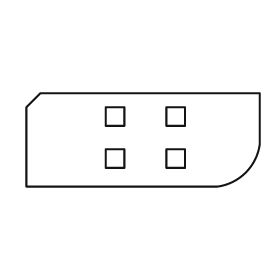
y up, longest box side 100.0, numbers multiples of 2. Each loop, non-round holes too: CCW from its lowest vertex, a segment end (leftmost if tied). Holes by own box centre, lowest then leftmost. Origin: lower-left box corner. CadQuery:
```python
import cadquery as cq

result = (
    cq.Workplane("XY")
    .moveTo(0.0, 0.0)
    .lineTo(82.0, 0.0)
    .threePointArc((94.0, 6.0), (100.0, 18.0))
    .lineTo(100.0, 40.0)
    .lineTo(6.0, 40.0)
    .lineTo(0.0, 34.0)
    .close()
    .moveTo(34.0, 8.0)
    .lineTo(42.0, 8.0)
    .lineTo(42.0, 16.0)
    .lineTo(34.0, 16.0)
    .close()
    .moveTo(60.0, 8.0)
    .lineTo(68.0, 8.0)
    .lineTo(68.0, 16.0)
    .lineTo(60.0, 16.0)
    .close()
    .moveTo(34.0, 26.0)
    .lineTo(42.0, 26.0)
    .lineTo(42.0, 34.0)
    .lineTo(34.0, 34.0)
    .close()
    .moveTo(60.0, 26.0)
    .lineTo(68.0, 26.0)
    .lineTo(68.0, 34.0)
    .lineTo(60.0, 34.0)
    .close()
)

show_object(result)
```